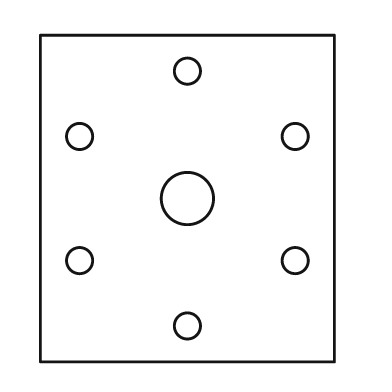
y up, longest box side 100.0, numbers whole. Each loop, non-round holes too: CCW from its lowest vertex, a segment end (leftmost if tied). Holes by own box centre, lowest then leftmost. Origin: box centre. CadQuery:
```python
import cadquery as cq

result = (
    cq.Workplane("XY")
    .moveTo(-45.0, -50.0)
    .lineTo(45.0, -50.0)
    .lineTo(45.0, 50.0)
    .lineTo(-45.0, 50.0)
    .close()
    .moveTo(0.0, -39.0)
    .circle(4.0)
    .moveTo(-33.0, -19.0)
    .circle(4.0)
    .moveTo(33.0, -19.0)
    .circle(4.0)
    .moveTo(0.0, 0.0)
    .circle(8.0)
    .moveTo(-33.0, 19.0)
    .circle(4.0)
    .moveTo(33.0, 19.0)
    .circle(4.0)
    .moveTo(0.0, 39.0)
    .circle(4.0)
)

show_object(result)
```